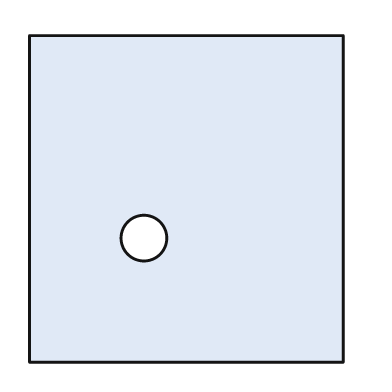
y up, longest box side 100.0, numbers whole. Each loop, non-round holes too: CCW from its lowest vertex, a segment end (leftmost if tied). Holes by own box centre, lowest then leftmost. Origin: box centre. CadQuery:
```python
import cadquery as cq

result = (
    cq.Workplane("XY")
    .moveTo(-48.0, -50.0)
    .lineTo(48.0, -50.0)
    .lineTo(48.0, 50.0)
    .lineTo(-48.0, 50.0)
    .close()
    .moveTo(-13.0, -12.0)
    .circle(7.0)
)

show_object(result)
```